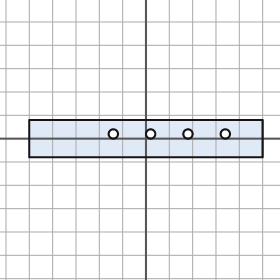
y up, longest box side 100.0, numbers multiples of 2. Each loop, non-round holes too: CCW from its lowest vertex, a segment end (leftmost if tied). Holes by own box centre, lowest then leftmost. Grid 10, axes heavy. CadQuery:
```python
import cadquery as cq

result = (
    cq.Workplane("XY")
    .moveTo(-50.0, -8.0)
    .lineTo(50.0, -8.0)
    .lineTo(50.0, 8.0)
    .lineTo(-50.0, 8.0)
    .close()
    .moveTo(-14.0, 2.0)
    .circle(2.0)
    .moveTo(2.0, 2.0)
    .circle(2.0)
    .moveTo(18.0, 2.0)
    .circle(2.0)
    .moveTo(34.0, 2.0)
    .circle(2.0)
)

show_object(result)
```